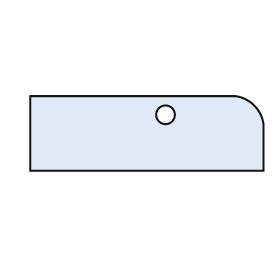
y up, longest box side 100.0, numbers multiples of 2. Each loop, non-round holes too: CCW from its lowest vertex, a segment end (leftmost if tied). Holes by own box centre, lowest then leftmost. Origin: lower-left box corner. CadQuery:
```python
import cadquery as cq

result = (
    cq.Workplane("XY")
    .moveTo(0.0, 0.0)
    .lineTo(100.0, 0.0)
    .lineTo(100.0, 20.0)
    .threePointArc((96.0, 28.0), (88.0, 32.0))
    .lineTo(0.0, 32.0)
    .close()
    .moveTo(58.0, 24.0)
    .circle(4.0)
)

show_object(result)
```